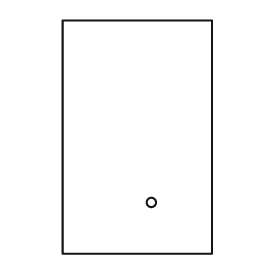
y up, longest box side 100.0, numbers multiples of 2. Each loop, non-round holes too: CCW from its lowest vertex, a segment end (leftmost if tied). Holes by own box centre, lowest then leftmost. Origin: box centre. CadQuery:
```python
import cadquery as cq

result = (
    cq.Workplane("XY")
    .moveTo(-32.0, -50.0)
    .lineTo(32.0, -50.0)
    .lineTo(32.0, 50.0)
    .lineTo(-32.0, 50.0)
    .close()
    .moveTo(6.0, -28.0)
    .circle(2.0)
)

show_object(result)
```